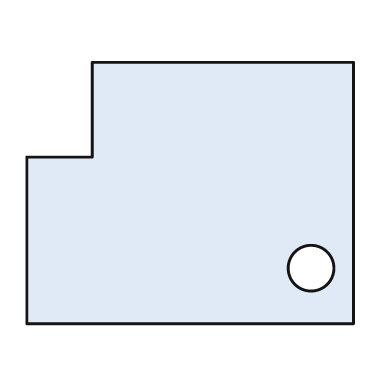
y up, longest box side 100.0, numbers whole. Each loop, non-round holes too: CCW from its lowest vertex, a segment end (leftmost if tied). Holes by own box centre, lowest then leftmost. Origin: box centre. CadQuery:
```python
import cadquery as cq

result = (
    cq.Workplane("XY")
    .moveTo(-50.0, -40.0)
    .lineTo(50.0, -40.0)
    .lineTo(50.0, 40.0)
    .lineTo(-30.0, 40.0)
    .lineTo(-30.0, 11.0)
    .lineTo(-50.0, 11.0)
    .close()
    .moveTo(37.0, -23.0)
    .circle(7.0)
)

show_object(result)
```